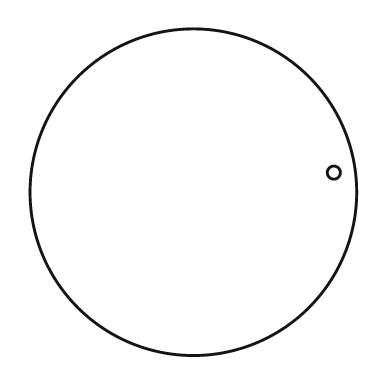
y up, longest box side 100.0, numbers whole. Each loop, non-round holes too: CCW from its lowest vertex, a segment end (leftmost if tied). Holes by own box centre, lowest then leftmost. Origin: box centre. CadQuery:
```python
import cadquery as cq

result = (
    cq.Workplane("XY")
    .moveTo(0.0, 0.0)
    .circle(50.0)
    .moveTo(43.0, 6.0)
    .circle(2.0)
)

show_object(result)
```